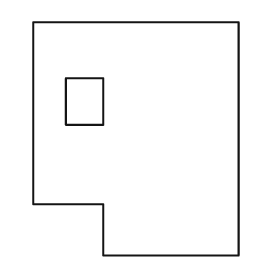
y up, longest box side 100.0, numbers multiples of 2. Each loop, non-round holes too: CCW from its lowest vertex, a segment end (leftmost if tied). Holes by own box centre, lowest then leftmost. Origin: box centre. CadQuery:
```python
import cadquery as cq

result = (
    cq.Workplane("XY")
    .moveTo(-14.0, -50.0)
    .lineTo(44.0, -50.0)
    .lineTo(44.0, 50.0)
    .lineTo(-44.0, 50.0)
    .lineTo(-44.0, -28.0)
    .lineTo(-14.0, -28.0)
    .close()
    .moveTo(-30.0, 6.0)
    .lineTo(-14.0, 6.0)
    .lineTo(-14.0, 26.0)
    .lineTo(-30.0, 26.0)
    .close()
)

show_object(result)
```